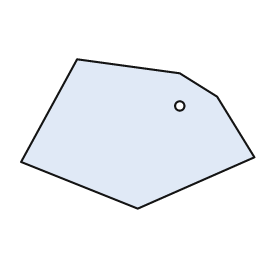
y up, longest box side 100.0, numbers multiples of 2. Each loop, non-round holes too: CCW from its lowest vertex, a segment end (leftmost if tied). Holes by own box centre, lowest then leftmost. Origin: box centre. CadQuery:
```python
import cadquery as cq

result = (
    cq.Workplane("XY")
    .moveTo(0.0, -32.0)
    .lineTo(50.0, -10.0)
    .lineTo(34.0, 16.0)
    .lineTo(18.0, 26.0)
    .lineTo(-26.0, 32.0)
    .lineTo(-50.0, -12.0)
    .close()
    .moveTo(18.0, 12.0)
    .circle(2.0)
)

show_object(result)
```